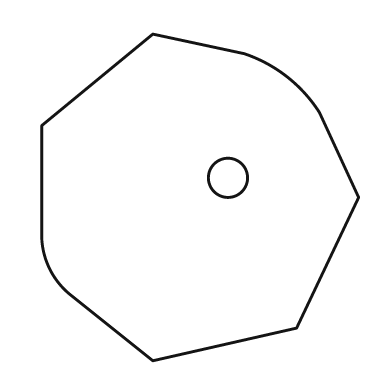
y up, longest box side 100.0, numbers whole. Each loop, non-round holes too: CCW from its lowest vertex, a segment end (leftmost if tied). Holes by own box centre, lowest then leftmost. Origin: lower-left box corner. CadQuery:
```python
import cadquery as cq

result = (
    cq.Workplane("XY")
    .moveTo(34.0, 0.0)
    .lineTo(78.0, 10.0)
    .lineTo(97.0, 50.0)
    .lineTo(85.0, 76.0)
    .threePointArc((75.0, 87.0), (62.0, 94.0))
    .lineTo(34.0, 100.0)
    .lineTo(0.0, 72.0)
    .lineTo(0.0, 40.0)
    .threePointArc((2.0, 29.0), (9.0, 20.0))
    .close()
    .moveTo(57.0, 56.0)
    .circle(6.0)
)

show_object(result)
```